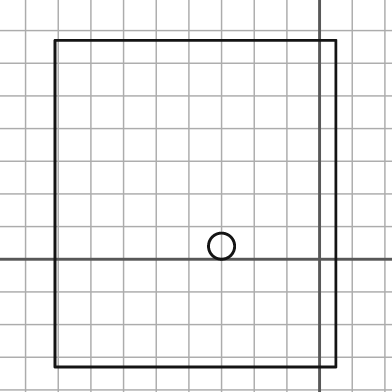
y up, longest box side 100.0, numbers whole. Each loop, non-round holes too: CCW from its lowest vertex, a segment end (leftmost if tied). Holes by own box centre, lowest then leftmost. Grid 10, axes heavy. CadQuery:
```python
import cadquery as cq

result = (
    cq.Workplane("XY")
    .moveTo(-81.0, -33.0)
    .lineTo(5.0, -33.0)
    .lineTo(5.0, 67.0)
    .lineTo(-81.0, 67.0)
    .close()
    .moveTo(-30.0, 4.0)
    .circle(4.0)
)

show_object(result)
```